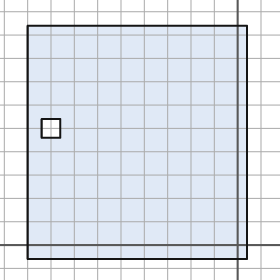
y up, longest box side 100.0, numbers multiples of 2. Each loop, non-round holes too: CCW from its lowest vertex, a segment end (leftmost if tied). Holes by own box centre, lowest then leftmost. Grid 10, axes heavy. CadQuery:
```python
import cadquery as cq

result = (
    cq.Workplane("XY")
    .moveTo(-90.0, -6.0)
    .lineTo(4.0, -6.0)
    .lineTo(4.0, 94.0)
    .lineTo(-90.0, 94.0)
    .close()
    .moveTo(-84.0, 46.0)
    .lineTo(-76.0, 46.0)
    .lineTo(-76.0, 54.0)
    .lineTo(-84.0, 54.0)
    .close()
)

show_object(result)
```